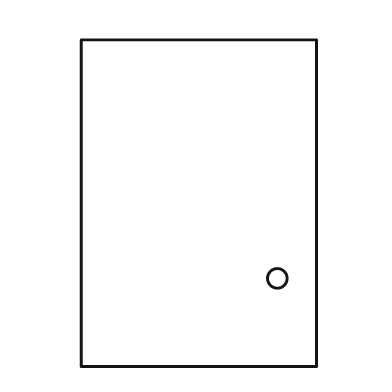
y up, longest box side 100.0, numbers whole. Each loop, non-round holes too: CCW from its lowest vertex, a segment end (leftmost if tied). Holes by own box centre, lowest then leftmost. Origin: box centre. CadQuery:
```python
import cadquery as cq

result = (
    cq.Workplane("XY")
    .moveTo(-36.0, -50.0)
    .lineTo(36.0, -50.0)
    .lineTo(36.0, 50.0)
    .lineTo(-36.0, 50.0)
    .close()
    .moveTo(24.0, -23.0)
    .circle(3.0)
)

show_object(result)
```